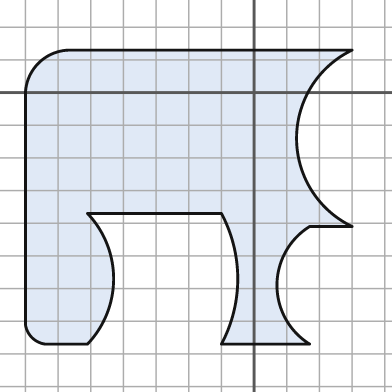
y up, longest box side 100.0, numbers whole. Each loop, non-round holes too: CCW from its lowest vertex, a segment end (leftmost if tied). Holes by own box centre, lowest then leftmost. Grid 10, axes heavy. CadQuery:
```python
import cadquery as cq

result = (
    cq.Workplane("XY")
    .moveTo(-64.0, -77.0)
    .lineTo(-51.0, -77.0)
    .threePointArc((-43.0, -57.0), (-51.0, -37.0))
    .lineTo(-10.0, -37.0)
    .threePointArc((-5.0, -57.0), (-10.0, -77.0))
    .lineTo(17.0, -77.0)
    .threePointArc((7.0, -59.0), (17.0, -41.0))
    .lineTo(30.0, -41.0)
    .threePointArc((13.0, -14.0), (30.0, 13.0))
    .lineTo(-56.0, 13.0)
    .threePointArc((-66.0, 9.0), (-70.0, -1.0))
    .lineTo(-70.0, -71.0)
    .threePointArc((-68.0, -75.0), (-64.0, -77.0))
    .close()
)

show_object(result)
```